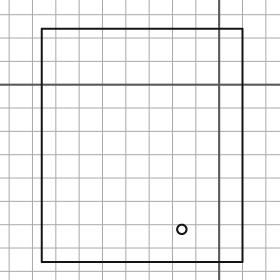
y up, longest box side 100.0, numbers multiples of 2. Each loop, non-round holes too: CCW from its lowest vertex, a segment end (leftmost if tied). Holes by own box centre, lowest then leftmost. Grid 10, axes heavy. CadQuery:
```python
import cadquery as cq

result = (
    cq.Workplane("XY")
    .moveTo(-76.0, -76.0)
    .lineTo(10.0, -76.0)
    .lineTo(10.0, 24.0)
    .lineTo(-76.0, 24.0)
    .close()
    .moveTo(-16.0, -62.0)
    .circle(2.0)
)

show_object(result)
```